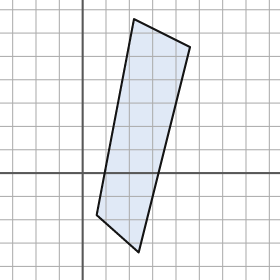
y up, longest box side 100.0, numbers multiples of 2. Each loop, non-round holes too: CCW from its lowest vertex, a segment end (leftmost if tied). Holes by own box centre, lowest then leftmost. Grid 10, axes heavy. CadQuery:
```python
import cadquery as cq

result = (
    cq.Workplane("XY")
    .moveTo(24.0, -34.0)
    .lineTo(46.0, 54.0)
    .lineTo(22.0, 66.0)
    .lineTo(6.0, -18.0)
    .close()
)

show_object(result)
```